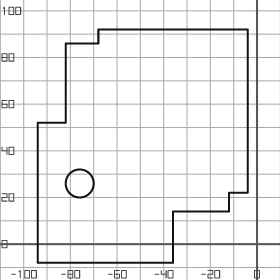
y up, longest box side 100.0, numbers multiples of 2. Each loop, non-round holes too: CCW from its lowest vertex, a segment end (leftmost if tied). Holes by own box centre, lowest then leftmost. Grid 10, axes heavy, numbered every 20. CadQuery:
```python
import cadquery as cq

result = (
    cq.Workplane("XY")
    .moveTo(-94.0, -8.0)
    .lineTo(-36.0, -8.0)
    .lineTo(-36.0, 14.0)
    .lineTo(-12.0, 14.0)
    .lineTo(-12.0, 22.0)
    .lineTo(-4.0, 22.0)
    .lineTo(-4.0, 92.0)
    .lineTo(-68.0, 92.0)
    .lineTo(-68.0, 86.0)
    .lineTo(-82.0, 86.0)
    .lineTo(-82.0, 52.0)
    .lineTo(-94.0, 52.0)
    .close()
    .moveTo(-76.0, 26.0)
    .circle(6.0)
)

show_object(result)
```